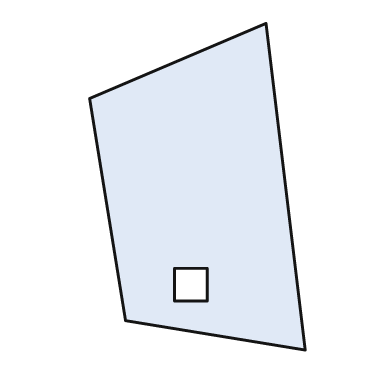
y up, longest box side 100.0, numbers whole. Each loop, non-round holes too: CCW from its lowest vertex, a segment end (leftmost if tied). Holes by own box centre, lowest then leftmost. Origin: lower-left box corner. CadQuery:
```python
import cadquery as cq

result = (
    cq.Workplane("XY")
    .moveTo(66.0, 0.0)
    .lineTo(54.0, 100.0)
    .lineTo(0.0, 77.0)
    .lineTo(11.0, 9.0)
    .close()
    .moveTo(26.0, 15.0)
    .lineTo(36.0, 15.0)
    .lineTo(36.0, 25.0)
    .lineTo(26.0, 25.0)
    .close()
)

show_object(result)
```